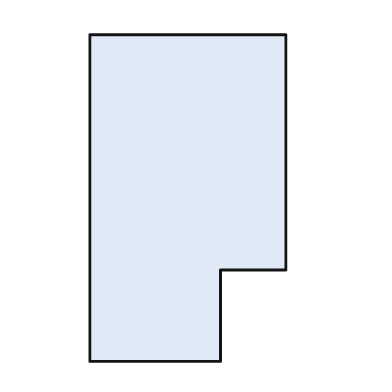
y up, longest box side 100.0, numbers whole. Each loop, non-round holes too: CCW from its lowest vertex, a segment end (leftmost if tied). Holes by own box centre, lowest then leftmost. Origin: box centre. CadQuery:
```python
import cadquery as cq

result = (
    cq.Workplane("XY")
    .moveTo(-30.0, -50.0)
    .lineTo(10.0, -50.0)
    .lineTo(10.0, -22.0)
    .lineTo(30.0, -22.0)
    .lineTo(30.0, 50.0)
    .lineTo(-30.0, 50.0)
    .close()
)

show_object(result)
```